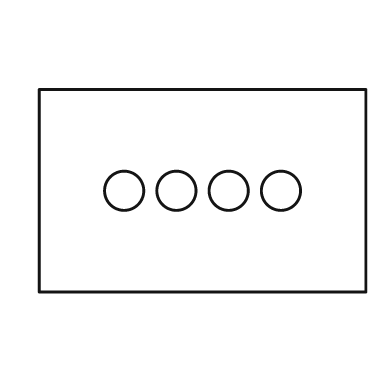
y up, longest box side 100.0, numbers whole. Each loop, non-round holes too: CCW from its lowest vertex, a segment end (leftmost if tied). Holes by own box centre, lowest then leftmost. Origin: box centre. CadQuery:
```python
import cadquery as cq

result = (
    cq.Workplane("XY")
    .moveTo(-50.0, -31.0)
    .lineTo(50.0, -31.0)
    .lineTo(50.0, 31.0)
    .lineTo(-50.0, 31.0)
    .close()
    .moveTo(-24.0, 0.0)
    .circle(6.0)
    .moveTo(-8.0, 0.0)
    .circle(6.0)
    .moveTo(8.0, 0.0)
    .circle(6.0)
    .moveTo(24.0, 0.0)
    .circle(6.0)
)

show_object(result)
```